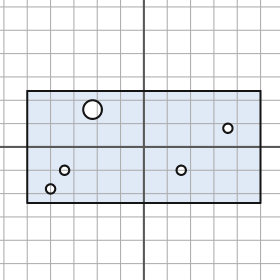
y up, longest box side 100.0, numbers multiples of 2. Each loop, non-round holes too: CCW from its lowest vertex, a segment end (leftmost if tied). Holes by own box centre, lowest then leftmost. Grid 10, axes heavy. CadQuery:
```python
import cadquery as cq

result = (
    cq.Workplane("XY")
    .moveTo(-50.0, -24.0)
    .lineTo(50.0, -24.0)
    .lineTo(50.0, 24.0)
    .lineTo(-50.0, 24.0)
    .close()
    .moveTo(-40.0, -18.0)
    .circle(2.0)
    .moveTo(-34.0, -10.0)
    .circle(2.0)
    .moveTo(16.0, -10.0)
    .circle(2.0)
    .moveTo(36.0, 8.0)
    .circle(2.0)
    .moveTo(-22.0, 16.0)
    .circle(4.0)
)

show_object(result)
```